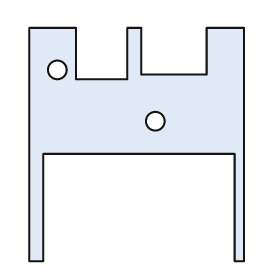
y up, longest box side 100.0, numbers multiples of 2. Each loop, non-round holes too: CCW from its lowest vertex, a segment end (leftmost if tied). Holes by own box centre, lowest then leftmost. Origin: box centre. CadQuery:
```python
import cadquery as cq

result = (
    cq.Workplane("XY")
    .moveTo(-46.0, -50.0)
    .lineTo(-40.0, -50.0)
    .lineTo(-40.0, -4.0)
    .lineTo(42.0, -4.0)
    .lineTo(42.0, -50.0)
    .lineTo(46.0, -50.0)
    .lineTo(46.0, 50.0)
    .lineTo(30.0, 50.0)
    .lineTo(30.0, 30.0)
    .lineTo(2.0, 30.0)
    .lineTo(2.0, 50.0)
    .lineTo(-4.0, 50.0)
    .lineTo(-4.0, 28.0)
    .lineTo(-26.0, 28.0)
    .lineTo(-26.0, 50.0)
    .lineTo(-46.0, 50.0)
    .close()
    .moveTo(8.0, 10.0)
    .circle(4.0)
    .moveTo(-34.0, 32.0)
    .circle(4.0)
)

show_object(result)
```